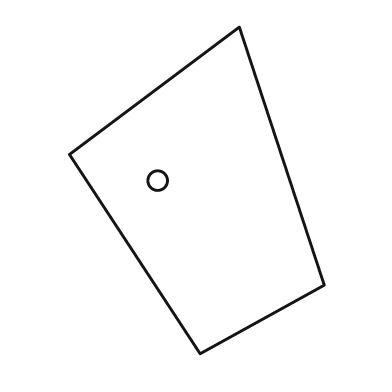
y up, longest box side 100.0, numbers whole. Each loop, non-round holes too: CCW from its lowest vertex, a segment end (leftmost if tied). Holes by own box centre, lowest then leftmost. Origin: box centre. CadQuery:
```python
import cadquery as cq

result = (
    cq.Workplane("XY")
    .moveTo(1.0, -50.0)
    .lineTo(39.0, -29.0)
    .lineTo(13.0, 50.0)
    .lineTo(-39.0, 11.0)
    .close()
    .moveTo(-12.0, 3.0)
    .circle(3.0)
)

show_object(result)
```